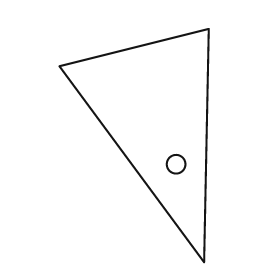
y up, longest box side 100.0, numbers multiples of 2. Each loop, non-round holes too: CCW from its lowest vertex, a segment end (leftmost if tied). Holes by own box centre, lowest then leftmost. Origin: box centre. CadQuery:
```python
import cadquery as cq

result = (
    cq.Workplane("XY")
    .moveTo(30.0, -50.0)
    .lineTo(32.0, 50.0)
    .lineTo(-32.0, 34.0)
    .close()
    .moveTo(18.0, -8.0)
    .circle(4.0)
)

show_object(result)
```